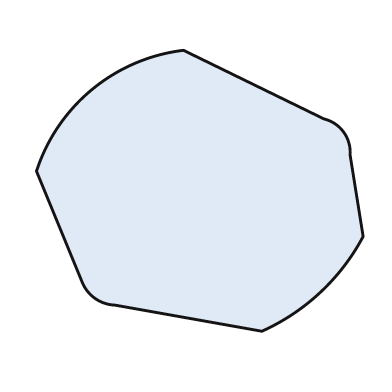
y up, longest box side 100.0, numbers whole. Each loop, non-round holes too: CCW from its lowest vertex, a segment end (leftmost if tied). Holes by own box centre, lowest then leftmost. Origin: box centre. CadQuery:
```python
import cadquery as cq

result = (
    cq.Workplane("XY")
    .moveTo(19.0, -43.0)
    .threePointArc((37.0, -31.0), (50.0, -14.0))
    .lineTo(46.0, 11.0)
    .threePointArc((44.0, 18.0), (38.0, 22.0))
    .lineTo(-5.0, 43.0)
    .threePointArc((-33.0, 31.0), (-50.0, 6.0))
    .lineTo(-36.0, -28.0)
    .threePointArc((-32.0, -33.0), (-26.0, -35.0))
    .close()
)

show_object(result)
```